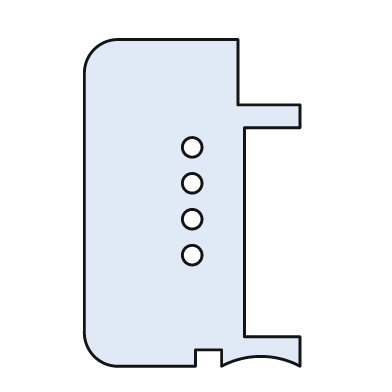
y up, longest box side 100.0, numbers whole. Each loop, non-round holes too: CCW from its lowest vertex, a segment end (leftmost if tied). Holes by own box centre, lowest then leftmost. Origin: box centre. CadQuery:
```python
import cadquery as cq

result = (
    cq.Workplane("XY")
    .moveTo(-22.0, -50.0)
    .lineTo(1.0, -50.0)
    .lineTo(1.0, -45.0)
    .lineTo(9.0, -45.0)
    .lineTo(9.0, -50.0)
    .threePointArc((21.0, -47.0), (33.0, -50.0))
    .lineTo(33.0, -41.0)
    .lineTo(16.0, -41.0)
    .lineTo(16.0, 23.0)
    .lineTo(33.0, 23.0)
    .lineTo(33.0, 30.0)
    .lineTo(14.0, 30.0)
    .lineTo(14.0, 50.0)
    .lineTo(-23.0, 50.0)
    .threePointArc((-30.0, 47.0), (-33.0, 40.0))
    .lineTo(-33.0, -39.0)
    .threePointArc((-30.0, -47.0), (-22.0, -50.0))
    .close()
    .moveTo(0.0, -16.0)
    .circle(3.0)
    .moveTo(0.0, -5.0)
    .circle(3.0)
    .moveTo(0.0, 6.0)
    .circle(3.0)
    .moveTo(0.0, 17.0)
    .circle(3.0)
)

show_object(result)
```